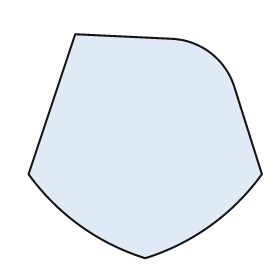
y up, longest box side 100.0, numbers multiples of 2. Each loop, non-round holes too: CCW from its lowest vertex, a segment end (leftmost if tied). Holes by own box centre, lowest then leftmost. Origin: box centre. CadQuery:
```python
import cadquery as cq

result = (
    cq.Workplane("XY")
    .moveTo(0.0, -48.0)
    .threePointArc((28.0, -34.0), (50.0, -12.0))
    .lineTo(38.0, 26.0)
    .threePointArc((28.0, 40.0), (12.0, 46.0))
    .lineTo(-30.0, 48.0)
    .lineTo(-50.0, -12.0)
    .threePointArc((-28.0, -34.0), (0.0, -48.0))
    .close()
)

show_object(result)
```